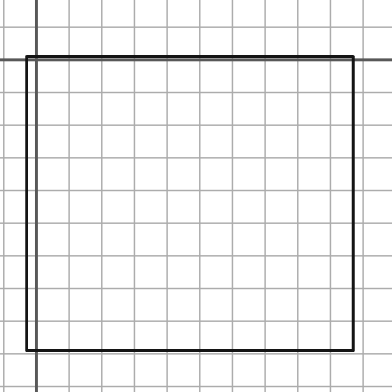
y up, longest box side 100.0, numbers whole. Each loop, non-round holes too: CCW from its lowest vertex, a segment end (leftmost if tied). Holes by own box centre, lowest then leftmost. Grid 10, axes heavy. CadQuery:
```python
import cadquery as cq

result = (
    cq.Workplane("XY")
    .moveTo(-3.0, -89.0)
    .lineTo(97.0, -89.0)
    .lineTo(97.0, 1.0)
    .lineTo(-3.0, 1.0)
    .close()
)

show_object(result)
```